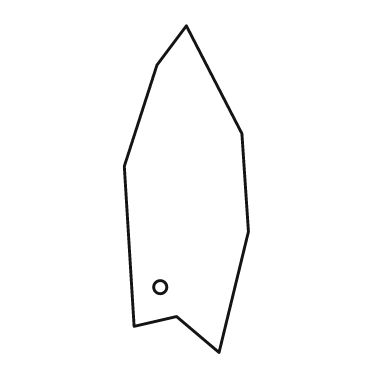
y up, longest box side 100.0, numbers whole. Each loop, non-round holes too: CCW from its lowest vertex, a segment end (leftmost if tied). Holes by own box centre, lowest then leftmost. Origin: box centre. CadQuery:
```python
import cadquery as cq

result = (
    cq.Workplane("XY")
    .moveTo(10.0, -50.0)
    .lineTo(19.0, -13.0)
    .lineTo(17.0, 17.0)
    .lineTo(0.0, 50.0)
    .lineTo(-9.0, 38.0)
    .lineTo(-19.0, 7.0)
    .lineTo(-16.0, -42.0)
    .lineTo(-3.0, -39.0)
    .close()
    .moveTo(-8.0, -30.0)
    .circle(2.0)
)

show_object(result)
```